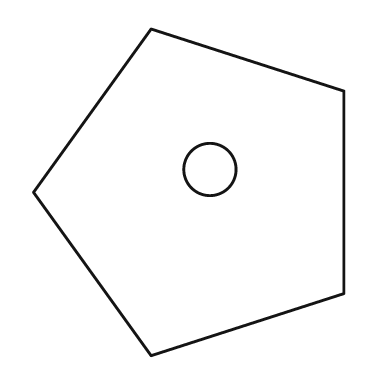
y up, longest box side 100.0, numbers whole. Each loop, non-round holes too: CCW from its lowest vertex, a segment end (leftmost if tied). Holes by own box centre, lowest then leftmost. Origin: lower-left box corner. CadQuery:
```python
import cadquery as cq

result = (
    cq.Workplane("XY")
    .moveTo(36.0, 0.0)
    .lineTo(95.0, 19.0)
    .lineTo(95.0, 81.0)
    .lineTo(36.0, 100.0)
    .lineTo(0.0, 50.0)
    .close()
    .moveTo(54.0, 57.0)
    .circle(8.0)
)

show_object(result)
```